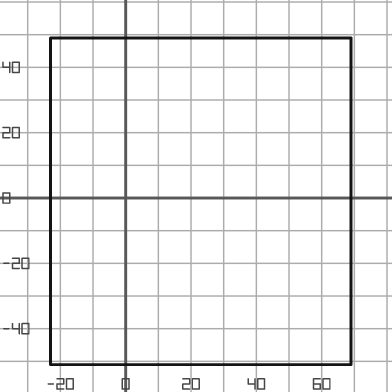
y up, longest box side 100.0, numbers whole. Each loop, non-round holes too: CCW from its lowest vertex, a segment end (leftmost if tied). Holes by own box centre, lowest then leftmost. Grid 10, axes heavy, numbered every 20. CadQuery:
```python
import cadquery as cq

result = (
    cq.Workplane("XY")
    .moveTo(-23.0, -51.0)
    .lineTo(69.0, -51.0)
    .lineTo(69.0, 49.0)
    .lineTo(-23.0, 49.0)
    .close()
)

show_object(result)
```